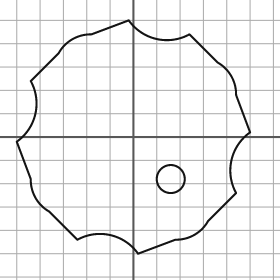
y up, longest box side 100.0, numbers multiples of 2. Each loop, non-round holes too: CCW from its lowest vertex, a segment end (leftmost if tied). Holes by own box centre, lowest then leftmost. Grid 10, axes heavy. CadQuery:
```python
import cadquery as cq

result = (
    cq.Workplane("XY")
    .moveTo(2.0, -50.0)
    .lineTo(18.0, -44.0)
    .threePointArc((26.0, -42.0), (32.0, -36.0))
    .lineTo(44.0, -24.0)
    .threePointArc((42.0, -10.0), (50.0, 2.0))
    .lineTo(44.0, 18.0)
    .threePointArc((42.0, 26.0), (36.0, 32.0))
    .lineTo(24.0, 44.0)
    .threePointArc((10.0, 42.0), (-2.0, 50.0))
    .lineTo(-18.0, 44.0)
    .threePointArc((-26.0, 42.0), (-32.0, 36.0))
    .lineTo(-44.0, 24.0)
    .threePointArc((-42.0, 10.0), (-50.0, -2.0))
    .lineTo(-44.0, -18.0)
    .threePointArc((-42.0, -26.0), (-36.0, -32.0))
    .lineTo(-24.0, -44.0)
    .threePointArc((-10.0, -42.0), (2.0, -50.0))
    .close()
    .moveTo(16.0, -18.0)
    .circle(6.0)
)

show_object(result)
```